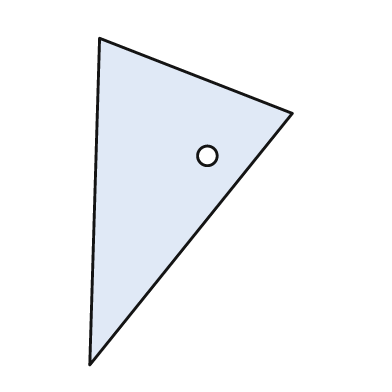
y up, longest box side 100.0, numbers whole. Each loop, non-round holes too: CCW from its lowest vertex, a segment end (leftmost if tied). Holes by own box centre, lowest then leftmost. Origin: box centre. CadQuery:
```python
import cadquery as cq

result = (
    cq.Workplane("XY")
    .moveTo(-31.0, -50.0)
    .lineTo(31.0, 27.0)
    .lineTo(-28.0, 50.0)
    .close()
    .moveTo(5.0, 14.0)
    .circle(3.0)
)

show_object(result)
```